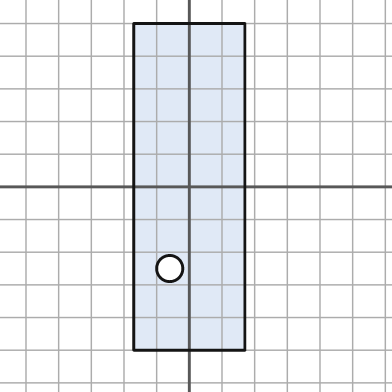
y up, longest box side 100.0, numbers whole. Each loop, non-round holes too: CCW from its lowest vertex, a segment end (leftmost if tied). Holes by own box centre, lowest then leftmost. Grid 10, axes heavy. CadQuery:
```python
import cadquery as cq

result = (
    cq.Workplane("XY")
    .moveTo(-17.0, -50.0)
    .lineTo(17.0, -50.0)
    .lineTo(17.0, 50.0)
    .lineTo(-17.0, 50.0)
    .close()
    .moveTo(-6.0, -25.0)
    .circle(4.0)
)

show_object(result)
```